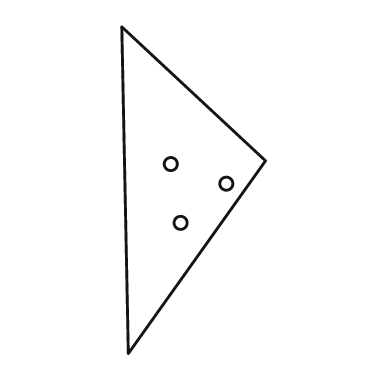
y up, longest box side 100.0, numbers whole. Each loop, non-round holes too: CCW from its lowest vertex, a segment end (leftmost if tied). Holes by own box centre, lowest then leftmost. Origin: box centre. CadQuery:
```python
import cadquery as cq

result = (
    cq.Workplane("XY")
    .moveTo(-20.0, -50.0)
    .lineTo(22.0, 9.0)
    .lineTo(-22.0, 50.0)
    .close()
    .moveTo(-4.0, -10.0)
    .circle(2.0)
    .moveTo(10.0, 2.0)
    .circle(2.0)
    .moveTo(-7.0, 8.0)
    .circle(2.0)
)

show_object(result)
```